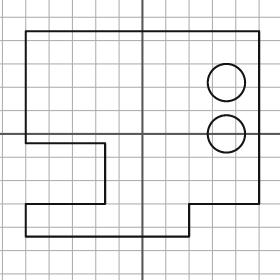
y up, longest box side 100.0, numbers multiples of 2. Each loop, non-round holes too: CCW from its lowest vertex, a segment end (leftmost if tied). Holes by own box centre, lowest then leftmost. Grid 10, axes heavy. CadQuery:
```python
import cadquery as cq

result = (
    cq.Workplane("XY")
    .moveTo(-50.0, -44.0)
    .lineTo(20.0, -44.0)
    .lineTo(20.0, -30.0)
    .lineTo(50.0, -30.0)
    .lineTo(50.0, 44.0)
    .lineTo(-50.0, 44.0)
    .lineTo(-50.0, -4.0)
    .lineTo(-16.0, -4.0)
    .lineTo(-16.0, -30.0)
    .lineTo(-50.0, -30.0)
    .close()
    .moveTo(36.0, 0.0)
    .circle(8.0)
    .moveTo(36.0, 22.0)
    .circle(8.0)
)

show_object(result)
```